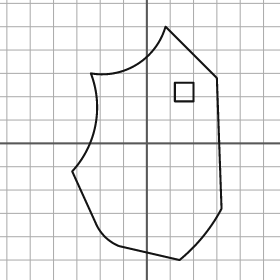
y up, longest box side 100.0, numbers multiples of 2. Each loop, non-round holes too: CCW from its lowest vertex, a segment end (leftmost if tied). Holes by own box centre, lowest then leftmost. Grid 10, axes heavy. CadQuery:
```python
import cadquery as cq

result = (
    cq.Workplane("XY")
    .moveTo(14.0, -50.0)
    .threePointArc((24.0, -40.0), (32.0, -28.0))
    .lineTo(30.0, 28.0)
    .lineTo(8.0, 50.0)
    .threePointArc((-4.0, 34.0), (-24.0, 30.0))
    .threePointArc((-22.0, 8.0), (-32.0, -12.0))
    .lineTo(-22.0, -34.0)
    .threePointArc((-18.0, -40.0), (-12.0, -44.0))
    .close()
    .moveTo(12.0, 18.0)
    .lineTo(20.0, 18.0)
    .lineTo(20.0, 26.0)
    .lineTo(12.0, 26.0)
    .close()
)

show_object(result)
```